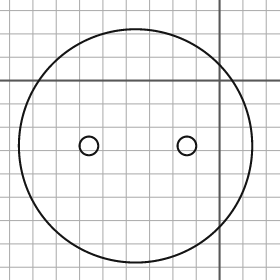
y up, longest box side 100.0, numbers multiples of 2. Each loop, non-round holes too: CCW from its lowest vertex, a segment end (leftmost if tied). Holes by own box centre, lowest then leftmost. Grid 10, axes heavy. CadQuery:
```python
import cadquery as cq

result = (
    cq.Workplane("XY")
    .moveTo(-36.0, -28.0)
    .circle(50.0)
    .moveTo(-56.0, -28.0)
    .circle(4.0)
    .moveTo(-14.0, -28.0)
    .circle(4.0)
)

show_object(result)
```